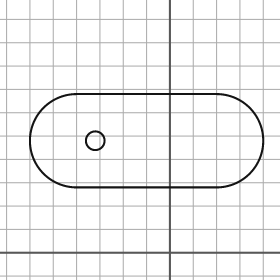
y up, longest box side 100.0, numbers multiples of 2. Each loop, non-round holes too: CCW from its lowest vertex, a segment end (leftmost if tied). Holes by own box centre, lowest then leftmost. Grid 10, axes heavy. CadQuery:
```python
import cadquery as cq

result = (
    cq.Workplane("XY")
    .moveTo(-40.0, 28.0)
    .lineTo(20.0, 28.0)
    .threePointArc((40.0, 48.0), (20.0, 68.0))
    .lineTo(-40.0, 68.0)
    .threePointArc((-60.0, 48.0), (-40.0, 28.0))
    .close()
    .moveTo(-32.0, 48.0)
    .circle(4.0)
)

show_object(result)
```